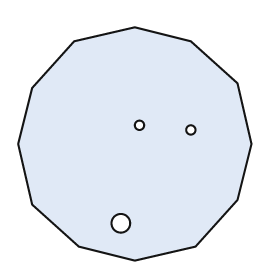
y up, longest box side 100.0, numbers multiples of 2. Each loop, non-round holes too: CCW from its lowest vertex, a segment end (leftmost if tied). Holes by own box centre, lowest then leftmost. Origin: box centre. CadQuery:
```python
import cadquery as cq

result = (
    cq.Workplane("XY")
    .moveTo(0.0, -50.0)
    .lineTo(26.0, -44.0)
    .lineTo(44.0, -24.0)
    .lineTo(50.0, 0.0)
    .lineTo(44.0, 26.0)
    .lineTo(24.0, 44.0)
    .lineTo(0.0, 50.0)
    .lineTo(-26.0, 44.0)
    .lineTo(-44.0, 24.0)
    .lineTo(-50.0, 0.0)
    .lineTo(-44.0, -26.0)
    .lineTo(-24.0, -44.0)
    .close()
    .moveTo(-6.0, -34.0)
    .circle(4.0)
    .moveTo(24.0, 6.0)
    .circle(2.0)
    .moveTo(2.0, 8.0)
    .circle(2.0)
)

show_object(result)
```